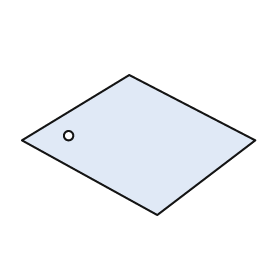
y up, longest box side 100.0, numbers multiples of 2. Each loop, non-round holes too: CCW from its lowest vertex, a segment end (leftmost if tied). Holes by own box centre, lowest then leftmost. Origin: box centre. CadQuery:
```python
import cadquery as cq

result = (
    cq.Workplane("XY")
    .moveTo(8.0, -30.0)
    .lineTo(50.0, 2.0)
    .lineTo(-4.0, 30.0)
    .lineTo(-50.0, 2.0)
    .close()
    .moveTo(-30.0, 4.0)
    .circle(2.0)
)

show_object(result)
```